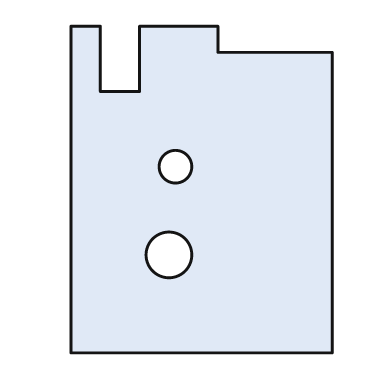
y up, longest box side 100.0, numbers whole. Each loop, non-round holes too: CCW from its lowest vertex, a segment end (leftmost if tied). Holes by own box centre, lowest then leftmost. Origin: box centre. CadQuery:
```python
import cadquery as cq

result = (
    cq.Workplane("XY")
    .moveTo(-40.0, -50.0)
    .lineTo(40.0, -50.0)
    .lineTo(40.0, 42.0)
    .lineTo(5.0, 42.0)
    .lineTo(5.0, 50.0)
    .lineTo(-19.0, 50.0)
    .lineTo(-19.0, 30.0)
    .lineTo(-31.0, 30.0)
    .lineTo(-31.0, 50.0)
    .lineTo(-40.0, 50.0)
    .close()
    .moveTo(-10.0, -20.0)
    .circle(7.0)
    .moveTo(-8.0, 7.0)
    .circle(5.0)
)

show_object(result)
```